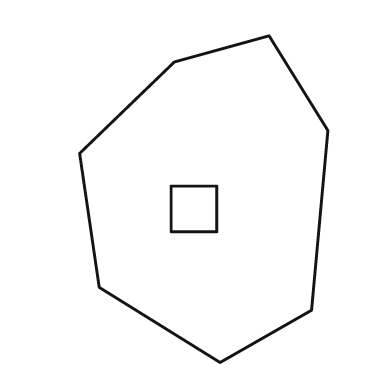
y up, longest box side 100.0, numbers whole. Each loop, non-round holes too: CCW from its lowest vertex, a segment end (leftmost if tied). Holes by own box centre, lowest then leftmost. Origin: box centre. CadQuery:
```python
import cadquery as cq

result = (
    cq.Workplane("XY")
    .moveTo(5.0, -50.0)
    .lineTo(33.0, -34.0)
    .lineTo(38.0, 21.0)
    .lineTo(20.0, 50.0)
    .lineTo(-9.0, 42.0)
    .lineTo(-38.0, 14.0)
    .lineTo(-32.0, -27.0)
    .close()
    .moveTo(-10.0, -10.0)
    .lineTo(4.0, -10.0)
    .lineTo(4.0, 4.0)
    .lineTo(-10.0, 4.0)
    .close()
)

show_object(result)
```